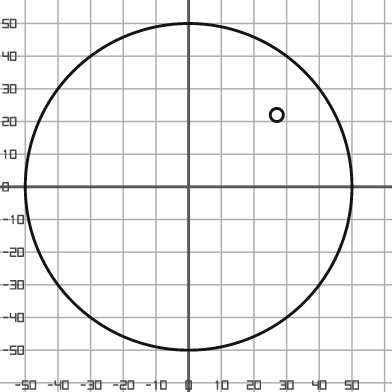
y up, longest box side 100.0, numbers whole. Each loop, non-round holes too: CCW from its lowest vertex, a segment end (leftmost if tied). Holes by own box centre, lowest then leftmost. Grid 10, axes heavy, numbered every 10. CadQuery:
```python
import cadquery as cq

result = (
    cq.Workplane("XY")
    .moveTo(0.0, 0.0)
    .circle(50.0)
    .moveTo(27.0, 22.0)
    .circle(2.0)
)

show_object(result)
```